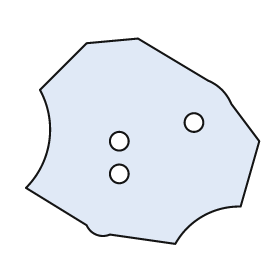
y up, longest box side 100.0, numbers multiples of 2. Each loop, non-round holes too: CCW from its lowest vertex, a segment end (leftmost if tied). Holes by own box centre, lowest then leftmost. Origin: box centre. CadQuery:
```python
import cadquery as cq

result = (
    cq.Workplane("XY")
    .moveTo(14.0, -44.0)
    .threePointArc((26.0, -32.0), (42.0, -28.0))
    .lineTo(50.0, 0.0)
    .lineTo(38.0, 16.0)
    .threePointArc((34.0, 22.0), (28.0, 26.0))
    .lineTo(-2.0, 44.0)
    .lineTo(-24.0, 42.0)
    .lineTo(-44.0, 22.0)
    .threePointArc((-40.0, 0.0), (-50.0, -20.0))
    .lineTo(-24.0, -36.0)
    .threePointArc((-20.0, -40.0), (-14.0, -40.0))
    .close()
    .moveTo(-10.0, -14.0)
    .circle(4.0)
    .moveTo(-10.0, 0.0)
    .circle(4.0)
    .moveTo(22.0, 8.0)
    .circle(4.0)
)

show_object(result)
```